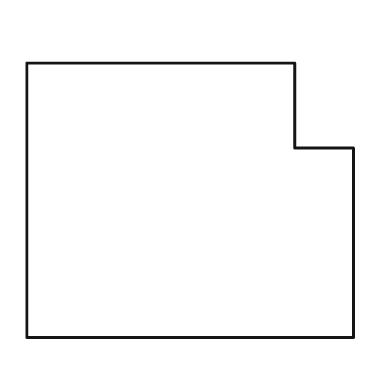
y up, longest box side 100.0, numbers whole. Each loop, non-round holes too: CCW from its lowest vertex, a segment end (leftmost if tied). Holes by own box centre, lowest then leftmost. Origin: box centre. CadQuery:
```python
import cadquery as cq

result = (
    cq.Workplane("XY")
    .moveTo(-50.0, -42.0)
    .lineTo(50.0, -42.0)
    .lineTo(50.0, 16.0)
    .lineTo(32.0, 16.0)
    .lineTo(32.0, 42.0)
    .lineTo(-50.0, 42.0)
    .close()
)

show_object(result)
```